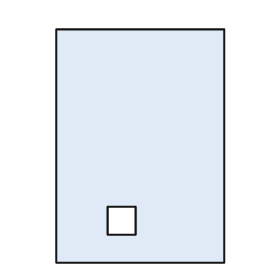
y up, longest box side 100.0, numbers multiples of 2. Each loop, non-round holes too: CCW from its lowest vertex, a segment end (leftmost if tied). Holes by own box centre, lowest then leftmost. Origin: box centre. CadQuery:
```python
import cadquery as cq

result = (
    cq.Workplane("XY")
    .moveTo(-36.0, -50.0)
    .lineTo(36.0, -50.0)
    .lineTo(36.0, 50.0)
    .lineTo(-36.0, 50.0)
    .close()
    .moveTo(-14.0, -38.0)
    .lineTo(-2.0, -38.0)
    .lineTo(-2.0, -26.0)
    .lineTo(-14.0, -26.0)
    .close()
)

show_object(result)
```